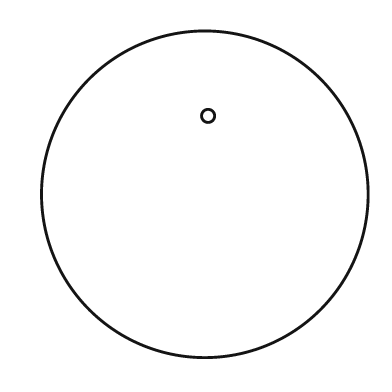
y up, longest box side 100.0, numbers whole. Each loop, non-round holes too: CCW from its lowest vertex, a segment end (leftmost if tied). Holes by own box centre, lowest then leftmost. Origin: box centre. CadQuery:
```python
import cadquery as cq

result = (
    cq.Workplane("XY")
    .moveTo(0.0, 0.0)
    .circle(50.0)
    .moveTo(1.0, 24.0)
    .circle(2.0)
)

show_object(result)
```